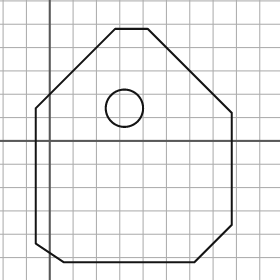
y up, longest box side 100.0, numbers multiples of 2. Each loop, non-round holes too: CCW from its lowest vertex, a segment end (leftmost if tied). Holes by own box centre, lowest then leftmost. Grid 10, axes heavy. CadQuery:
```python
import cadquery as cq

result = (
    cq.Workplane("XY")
    .moveTo(6.0, -52.0)
    .lineTo(62.0, -52.0)
    .lineTo(78.0, -36.0)
    .lineTo(78.0, 12.0)
    .lineTo(42.0, 48.0)
    .lineTo(28.0, 48.0)
    .lineTo(-6.0, 14.0)
    .lineTo(-6.0, -44.0)
    .close()
    .moveTo(32.0, 14.0)
    .circle(8.0)
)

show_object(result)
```